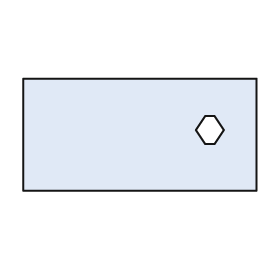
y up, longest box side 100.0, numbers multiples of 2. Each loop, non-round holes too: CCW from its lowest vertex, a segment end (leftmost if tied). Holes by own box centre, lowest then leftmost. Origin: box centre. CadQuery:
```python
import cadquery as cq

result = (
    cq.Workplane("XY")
    .moveTo(-50.0, -24.0)
    .lineTo(50.0, -24.0)
    .lineTo(50.0, 24.0)
    .lineTo(-50.0, 24.0)
    .close()
    .moveTo(28.0, -4.0)
    .lineTo(32.0, -4.0)
    .lineTo(36.0, 2.0)
    .lineTo(32.0, 8.0)
    .lineTo(28.0, 8.0)
    .lineTo(24.0, 2.0)
    .close()
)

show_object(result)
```